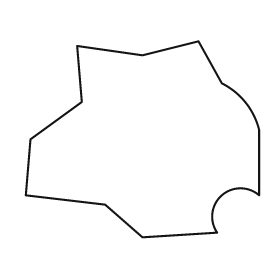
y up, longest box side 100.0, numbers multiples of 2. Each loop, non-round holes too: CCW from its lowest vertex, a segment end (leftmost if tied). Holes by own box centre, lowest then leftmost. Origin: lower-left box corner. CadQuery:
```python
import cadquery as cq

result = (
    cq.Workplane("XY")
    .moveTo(50.0, 0.0)
    .lineTo(82.0, 2.0)
    .threePointArc((84.0, 18.0), (100.0, 18.0))
    .lineTo(100.0, 46.0)
    .threePointArc((94.0, 58.0), (84.0, 66.0))
    .lineTo(74.0, 84.0)
    .lineTo(50.0, 78.0)
    .lineTo(22.0, 82.0)
    .lineTo(24.0, 58.0)
    .lineTo(2.0, 42.0)
    .lineTo(0.0, 18.0)
    .lineTo(34.0, 14.0)
    .close()
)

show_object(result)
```